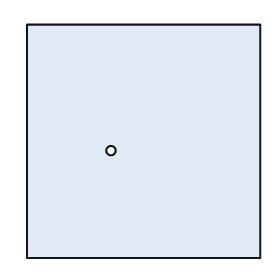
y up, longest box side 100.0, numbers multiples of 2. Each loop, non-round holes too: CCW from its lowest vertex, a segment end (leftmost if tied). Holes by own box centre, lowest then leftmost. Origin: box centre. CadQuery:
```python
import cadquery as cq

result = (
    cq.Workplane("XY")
    .moveTo(-50.0, -50.0)
    .lineTo(50.0, -50.0)
    .lineTo(50.0, 50.0)
    .lineTo(-50.0, 50.0)
    .close()
    .moveTo(-14.0, -4.0)
    .circle(2.0)
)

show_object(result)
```